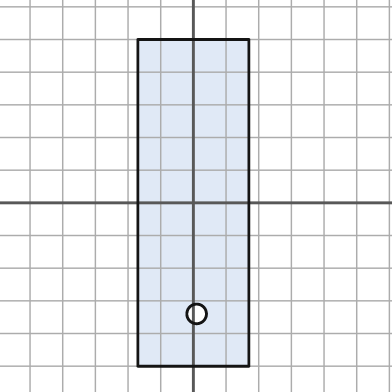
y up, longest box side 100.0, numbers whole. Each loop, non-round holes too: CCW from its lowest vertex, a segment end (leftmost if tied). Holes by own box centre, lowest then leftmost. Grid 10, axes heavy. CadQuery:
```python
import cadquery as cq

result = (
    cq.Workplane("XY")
    .moveTo(-17.0, -50.0)
    .lineTo(17.0, -50.0)
    .lineTo(17.0, 50.0)
    .lineTo(-17.0, 50.0)
    .close()
    .moveTo(1.0, -34.0)
    .circle(3.0)
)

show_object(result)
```